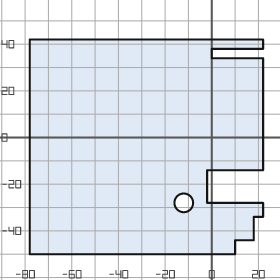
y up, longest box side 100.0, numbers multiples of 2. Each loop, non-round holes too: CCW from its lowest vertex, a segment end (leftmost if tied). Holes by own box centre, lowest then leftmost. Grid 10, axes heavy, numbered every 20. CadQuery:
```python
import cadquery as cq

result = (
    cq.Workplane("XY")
    .moveTo(-78.0, -50.0)
    .lineTo(10.0, -50.0)
    .lineTo(10.0, -44.0)
    .lineTo(18.0, -44.0)
    .lineTo(18.0, -34.0)
    .lineTo(22.0, -34.0)
    .lineTo(22.0, -28.0)
    .lineTo(-2.0, -28.0)
    .lineTo(-2.0, -14.0)
    .lineTo(22.0, -14.0)
    .lineTo(22.0, 34.0)
    .lineTo(0.0, 34.0)
    .lineTo(0.0, 38.0)
    .lineTo(22.0, 38.0)
    .lineTo(22.0, 42.0)
    .lineTo(-78.0, 42.0)
    .close()
    .moveTo(-12.0, -28.0)
    .circle(4.0)
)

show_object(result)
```